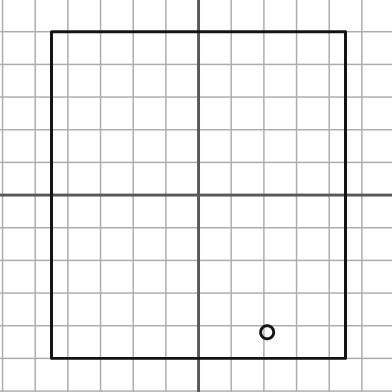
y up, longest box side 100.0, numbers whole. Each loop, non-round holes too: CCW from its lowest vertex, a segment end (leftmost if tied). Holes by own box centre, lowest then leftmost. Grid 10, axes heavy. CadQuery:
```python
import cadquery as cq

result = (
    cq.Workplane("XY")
    .moveTo(-45.0, -50.0)
    .lineTo(45.0, -50.0)
    .lineTo(45.0, 50.0)
    .lineTo(-45.0, 50.0)
    .close()
    .moveTo(21.0, -42.0)
    .circle(2.0)
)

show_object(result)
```